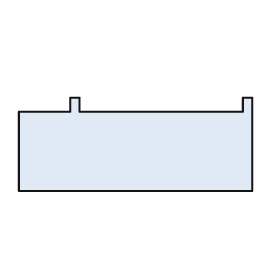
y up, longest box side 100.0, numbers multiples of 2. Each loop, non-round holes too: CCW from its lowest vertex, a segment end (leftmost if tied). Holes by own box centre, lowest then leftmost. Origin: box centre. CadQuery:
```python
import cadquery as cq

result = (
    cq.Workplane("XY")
    .moveTo(-50.0, -20.0)
    .lineTo(50.0, -20.0)
    .lineTo(50.0, 20.0)
    .lineTo(46.0, 20.0)
    .lineTo(46.0, 14.0)
    .lineTo(-24.0, 14.0)
    .lineTo(-24.0, 20.0)
    .lineTo(-28.0, 20.0)
    .lineTo(-28.0, 14.0)
    .lineTo(-50.0, 14.0)
    .close()
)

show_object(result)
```